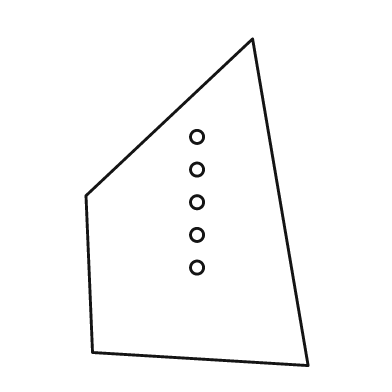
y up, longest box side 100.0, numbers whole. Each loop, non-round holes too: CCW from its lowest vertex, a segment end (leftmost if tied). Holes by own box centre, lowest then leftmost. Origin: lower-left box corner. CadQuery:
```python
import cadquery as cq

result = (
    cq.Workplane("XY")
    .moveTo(68.0, 0.0)
    .lineTo(51.0, 100.0)
    .lineTo(0.0, 52.0)
    .lineTo(2.0, 4.0)
    .close()
    .moveTo(34.0, 30.0)
    .circle(2.0)
    .moveTo(34.0, 40.0)
    .circle(2.0)
    .moveTo(34.0, 50.0)
    .circle(2.0)
    .moveTo(34.0, 60.0)
    .circle(2.0)
    .moveTo(34.0, 70.0)
    .circle(2.0)
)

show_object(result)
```